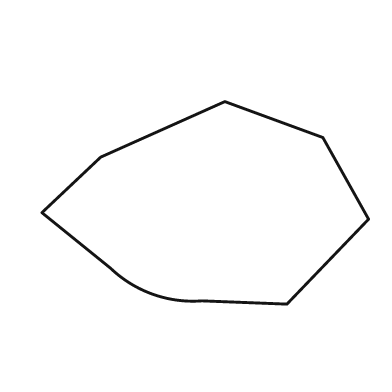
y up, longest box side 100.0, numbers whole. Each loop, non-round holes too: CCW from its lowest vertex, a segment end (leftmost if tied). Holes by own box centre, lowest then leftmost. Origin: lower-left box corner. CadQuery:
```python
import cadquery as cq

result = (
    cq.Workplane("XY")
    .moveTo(75.0, 0.0)
    .lineTo(100.0, 26.0)
    .lineTo(86.0, 51.0)
    .lineTo(56.0, 62.0)
    .lineTo(18.0, 45.0)
    .lineTo(0.0, 28.0)
    .lineTo(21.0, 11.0)
    .threePointArc((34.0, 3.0), (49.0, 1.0))
    .close()
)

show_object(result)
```